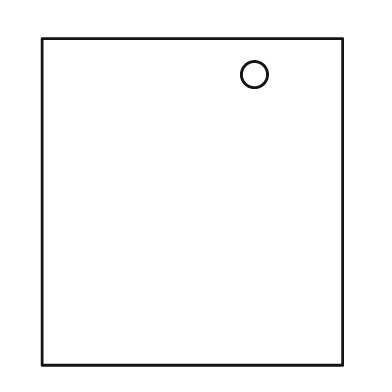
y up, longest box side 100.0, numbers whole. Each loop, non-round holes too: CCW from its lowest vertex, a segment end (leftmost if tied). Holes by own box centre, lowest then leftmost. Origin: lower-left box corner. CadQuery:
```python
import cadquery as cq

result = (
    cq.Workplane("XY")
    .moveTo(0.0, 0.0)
    .lineTo(92.0, 0.0)
    .lineTo(92.0, 100.0)
    .lineTo(0.0, 100.0)
    .close()
    .moveTo(65.0, 89.0)
    .circle(4.0)
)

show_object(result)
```